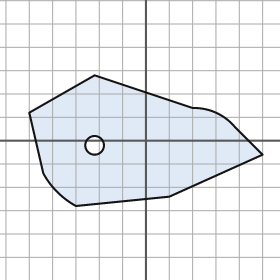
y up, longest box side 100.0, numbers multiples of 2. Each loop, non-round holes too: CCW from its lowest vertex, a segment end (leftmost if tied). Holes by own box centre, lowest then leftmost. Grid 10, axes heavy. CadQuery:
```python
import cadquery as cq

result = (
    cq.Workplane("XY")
    .moveTo(-30.0, -28.0)
    .lineTo(10.0, -24.0)
    .lineTo(50.0, -6.0)
    .lineTo(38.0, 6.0)
    .threePointArc((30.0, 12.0), (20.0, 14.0))
    .lineTo(-22.0, 28.0)
    .lineTo(-50.0, 12.0)
    .lineTo(-44.0, -14.0)
    .threePointArc((-38.0, -22.0), (-30.0, -28.0))
    .close()
    .moveTo(-22.0, -2.0)
    .circle(4.0)
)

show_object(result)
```